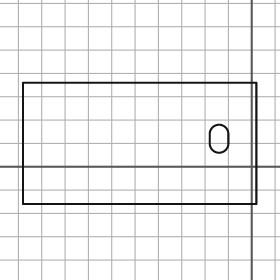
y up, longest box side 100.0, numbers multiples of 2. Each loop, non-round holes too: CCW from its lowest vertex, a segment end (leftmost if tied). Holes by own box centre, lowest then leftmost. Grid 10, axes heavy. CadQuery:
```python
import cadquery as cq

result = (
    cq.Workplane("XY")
    .moveTo(-98.0, -16.0)
    .lineTo(2.0, -16.0)
    .lineTo(2.0, 36.0)
    .lineTo(-98.0, 36.0)
    .close()
    .moveTo(-18.0, 10.0)
    .threePointArc((-14.0, 6.0), (-10.0, 10.0))
    .lineTo(-10.0, 14.0)
    .threePointArc((-14.0, 18.0), (-18.0, 14.0))
    .close()
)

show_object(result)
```